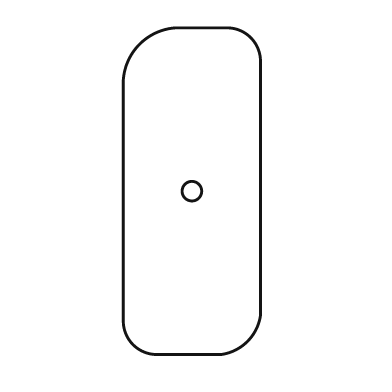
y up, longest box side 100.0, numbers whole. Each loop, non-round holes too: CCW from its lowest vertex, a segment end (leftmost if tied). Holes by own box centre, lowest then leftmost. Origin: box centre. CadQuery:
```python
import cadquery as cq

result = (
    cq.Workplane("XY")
    .moveTo(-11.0, -50.0)
    .lineTo(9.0, -50.0)
    .threePointArc((17.0, -46.0), (21.0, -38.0))
    .lineTo(21.0, 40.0)
    .threePointArc((18.0, 47.0), (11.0, 50.0))
    .lineTo(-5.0, 50.0)
    .threePointArc((-16.0, 45.0), (-21.0, 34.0))
    .lineTo(-21.0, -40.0)
    .threePointArc((-18.0, -47.0), (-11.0, -50.0))
    .close()
    .moveTo(0.0, 0.0)
    .circle(3.0)
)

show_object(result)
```